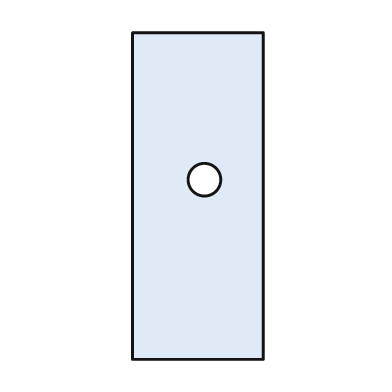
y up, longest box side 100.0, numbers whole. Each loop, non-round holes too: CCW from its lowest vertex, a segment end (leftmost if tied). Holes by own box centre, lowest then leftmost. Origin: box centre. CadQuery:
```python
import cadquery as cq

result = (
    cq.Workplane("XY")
    .moveTo(-20.0, -50.0)
    .lineTo(20.0, -50.0)
    .lineTo(20.0, 50.0)
    .lineTo(-20.0, 50.0)
    .close()
    .moveTo(2.0, 5.0)
    .circle(5.0)
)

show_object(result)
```